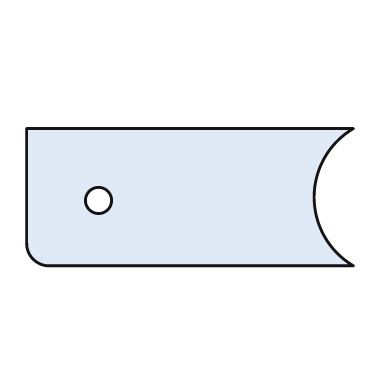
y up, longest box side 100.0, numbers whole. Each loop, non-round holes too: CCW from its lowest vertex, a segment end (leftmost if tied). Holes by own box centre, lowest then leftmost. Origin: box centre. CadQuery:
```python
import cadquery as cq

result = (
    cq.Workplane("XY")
    .moveTo(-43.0, -21.0)
    .lineTo(50.0, -21.0)
    .threePointArc((38.0, 0.0), (50.0, 21.0))
    .lineTo(-50.0, 21.0)
    .lineTo(-50.0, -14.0)
    .threePointArc((-48.0, -19.0), (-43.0, -21.0))
    .close()
    .moveTo(-28.0, -1.0)
    .circle(4.0)
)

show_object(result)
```